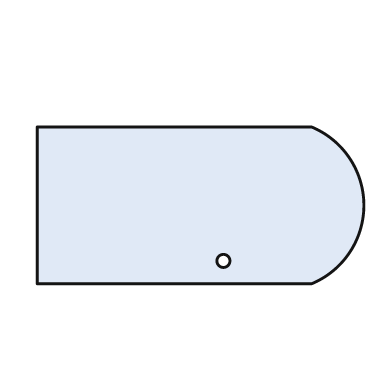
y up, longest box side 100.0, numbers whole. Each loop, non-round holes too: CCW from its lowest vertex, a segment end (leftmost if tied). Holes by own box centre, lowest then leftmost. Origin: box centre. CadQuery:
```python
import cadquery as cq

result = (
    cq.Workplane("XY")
    .moveTo(-50.0, -24.0)
    .lineTo(34.0, -24.0)
    .threePointArc((50.0, 0.0), (34.0, 24.0))
    .lineTo(-50.0, 24.0)
    .close()
    .moveTo(7.0, -17.0)
    .circle(2.0)
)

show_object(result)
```